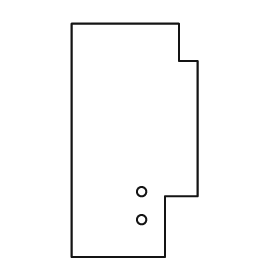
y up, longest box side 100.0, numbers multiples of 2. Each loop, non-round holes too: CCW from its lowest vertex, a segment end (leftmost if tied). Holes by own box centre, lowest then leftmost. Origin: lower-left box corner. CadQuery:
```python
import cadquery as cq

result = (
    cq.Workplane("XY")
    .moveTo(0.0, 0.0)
    .lineTo(40.0, 0.0)
    .lineTo(40.0, 26.0)
    .lineTo(54.0, 26.0)
    .lineTo(54.0, 84.0)
    .lineTo(46.0, 84.0)
    .lineTo(46.0, 100.0)
    .lineTo(0.0, 100.0)
    .close()
    .moveTo(30.0, 16.0)
    .circle(2.0)
    .moveTo(30.0, 28.0)
    .circle(2.0)
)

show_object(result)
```